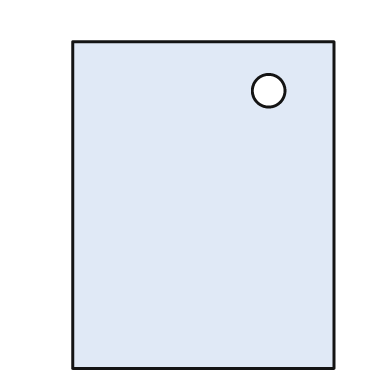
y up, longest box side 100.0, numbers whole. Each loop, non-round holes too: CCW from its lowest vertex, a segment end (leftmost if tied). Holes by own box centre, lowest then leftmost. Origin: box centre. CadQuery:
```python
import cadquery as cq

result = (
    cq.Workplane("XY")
    .moveTo(-40.0, -50.0)
    .lineTo(40.0, -50.0)
    .lineTo(40.0, 50.0)
    .lineTo(-40.0, 50.0)
    .close()
    .moveTo(20.0, 35.0)
    .circle(5.0)
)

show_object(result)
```